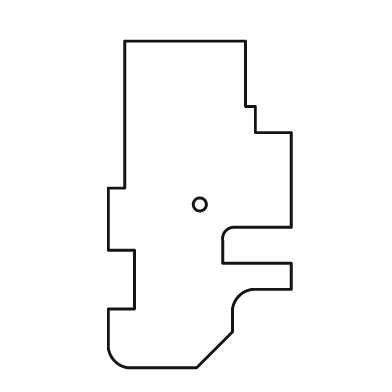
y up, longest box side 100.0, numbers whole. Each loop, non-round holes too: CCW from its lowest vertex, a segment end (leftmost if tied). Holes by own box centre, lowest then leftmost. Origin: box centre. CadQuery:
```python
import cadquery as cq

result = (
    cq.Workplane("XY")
    .moveTo(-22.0, -50.0)
    .lineTo(-1.0, -50.0)
    .lineTo(10.0, -39.0)
    .lineTo(10.0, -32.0)
    .threePointArc((12.0, -28.0), (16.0, -26.0))
    .lineTo(28.0, -26.0)
    .lineTo(28.0, -18.0)
    .lineTo(7.0, -18.0)
    .lineTo(7.0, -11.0)
    .threePointArc((8.0, -8.0), (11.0, -7.0))
    .lineTo(28.0, -7.0)
    .lineTo(28.0, 22.0)
    .lineTo(17.0, 22.0)
    .lineTo(17.0, 30.0)
    .lineTo(14.0, 30.0)
    .lineTo(14.0, 50.0)
    .lineTo(-23.0, 50.0)
    .lineTo(-23.0, 5.0)
    .lineTo(-28.0, 5.0)
    .lineTo(-28.0, -14.0)
    .lineTo(-20.0, -14.0)
    .lineTo(-20.0, -32.0)
    .lineTo(-28.0, -32.0)
    .lineTo(-28.0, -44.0)
    .threePointArc((-26.0, -48.0), (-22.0, -50.0))
    .close()
    .moveTo(0.0, 0.0)
    .circle(2.0)
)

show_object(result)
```